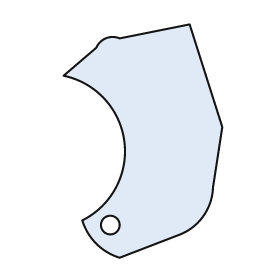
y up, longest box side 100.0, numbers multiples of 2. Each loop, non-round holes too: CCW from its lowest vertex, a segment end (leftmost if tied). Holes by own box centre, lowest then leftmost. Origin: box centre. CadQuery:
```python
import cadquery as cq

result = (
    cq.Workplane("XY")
    .moveTo(-10.0, -50.0)
    .lineTo(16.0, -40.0)
    .threePointArc((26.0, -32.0), (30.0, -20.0))
    .lineTo(34.0, 6.0)
    .lineTo(20.0, 50.0)
    .lineTo(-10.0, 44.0)
    .threePointArc((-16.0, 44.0), (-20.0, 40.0))
    .lineTo(-34.0, 28.0)
    .threePointArc((-8.0, 0.0), (-26.0, -34.0))
    .threePointArc((-20.0, -44.0), (-10.0, -50.0))
    .close()
    .moveTo(-14.0, -36.0)
    .circle(4.0)
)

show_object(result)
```